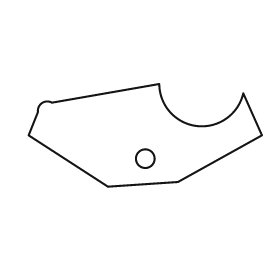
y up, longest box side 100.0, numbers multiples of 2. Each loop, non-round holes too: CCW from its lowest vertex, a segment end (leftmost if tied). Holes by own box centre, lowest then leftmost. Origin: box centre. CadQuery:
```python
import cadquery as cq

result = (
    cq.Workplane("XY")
    .moveTo(-16.0, -22.0)
    .lineTo(14.0, -20.0)
    .lineTo(50.0, 0.0)
    .lineTo(42.0, 18.0)
    .threePointArc((22.0, 4.0), (6.0, 22.0))
    .lineTo(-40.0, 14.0)
    .threePointArc((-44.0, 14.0), (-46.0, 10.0))
    .lineTo(-50.0, 0.0)
    .close()
    .moveTo(0.0, -10.0)
    .circle(4.0)
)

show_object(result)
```